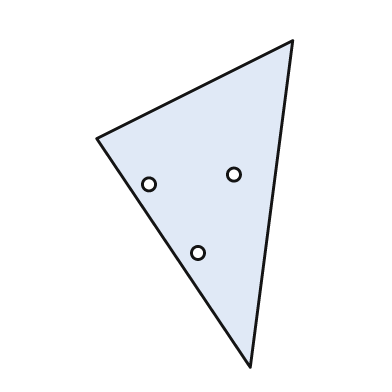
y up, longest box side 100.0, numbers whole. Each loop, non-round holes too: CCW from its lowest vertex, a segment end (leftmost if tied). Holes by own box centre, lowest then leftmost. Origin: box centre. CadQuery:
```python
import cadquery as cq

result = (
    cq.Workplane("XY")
    .moveTo(17.0, -50.0)
    .lineTo(30.0, 50.0)
    .lineTo(-30.0, 20.0)
    .close()
    .moveTo(1.0, -15.0)
    .circle(2.0)
    .moveTo(-14.0, 6.0)
    .circle(2.0)
    .moveTo(12.0, 9.0)
    .circle(2.0)
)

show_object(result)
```